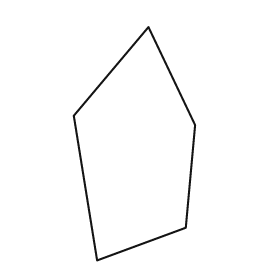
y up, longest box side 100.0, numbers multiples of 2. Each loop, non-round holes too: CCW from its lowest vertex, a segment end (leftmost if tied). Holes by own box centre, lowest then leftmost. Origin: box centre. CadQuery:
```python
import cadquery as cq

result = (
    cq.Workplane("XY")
    .moveTo(-16.0, -50.0)
    .lineTo(22.0, -36.0)
    .lineTo(26.0, 8.0)
    .lineTo(6.0, 50.0)
    .lineTo(-26.0, 12.0)
    .close()
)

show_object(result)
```